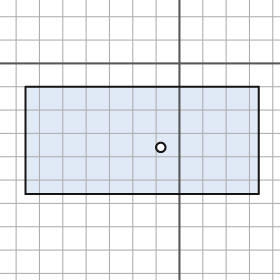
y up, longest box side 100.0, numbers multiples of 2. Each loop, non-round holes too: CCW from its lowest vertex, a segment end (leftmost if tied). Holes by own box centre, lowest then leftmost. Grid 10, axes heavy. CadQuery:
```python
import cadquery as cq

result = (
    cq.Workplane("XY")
    .moveTo(-66.0, -56.0)
    .lineTo(34.0, -56.0)
    .lineTo(34.0, -10.0)
    .lineTo(-66.0, -10.0)
    .close()
    .moveTo(-8.0, -36.0)
    .circle(2.0)
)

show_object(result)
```